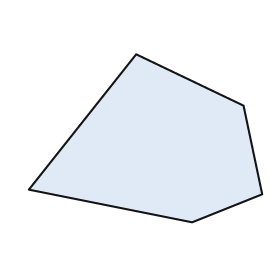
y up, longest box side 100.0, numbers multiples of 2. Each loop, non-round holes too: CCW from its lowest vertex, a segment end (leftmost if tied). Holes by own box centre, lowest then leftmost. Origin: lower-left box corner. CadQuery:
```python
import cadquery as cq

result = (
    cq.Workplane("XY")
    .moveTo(70.0, 0.0)
    .lineTo(100.0, 12.0)
    .lineTo(92.0, 50.0)
    .lineTo(46.0, 72.0)
    .lineTo(0.0, 14.0)
    .close()
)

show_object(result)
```